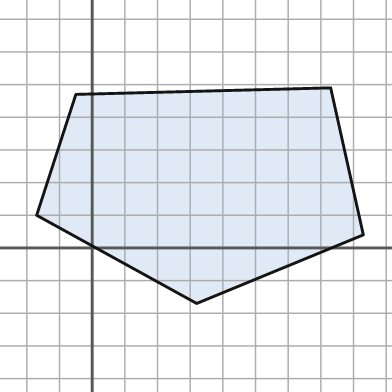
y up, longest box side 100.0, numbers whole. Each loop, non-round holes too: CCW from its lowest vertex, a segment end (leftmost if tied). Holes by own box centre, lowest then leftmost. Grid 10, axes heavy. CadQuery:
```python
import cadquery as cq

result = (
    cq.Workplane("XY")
    .moveTo(32.0, -17.0)
    .lineTo(83.0, 4.0)
    .lineTo(73.0, 49.0)
    .lineTo(-5.0, 47.0)
    .lineTo(-17.0, 10.0)
    .close()
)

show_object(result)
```